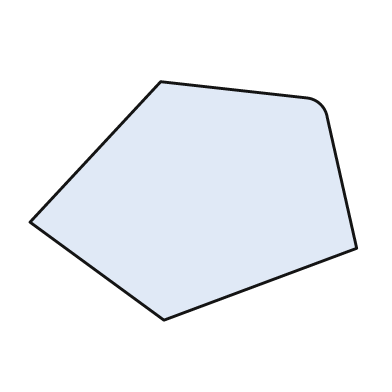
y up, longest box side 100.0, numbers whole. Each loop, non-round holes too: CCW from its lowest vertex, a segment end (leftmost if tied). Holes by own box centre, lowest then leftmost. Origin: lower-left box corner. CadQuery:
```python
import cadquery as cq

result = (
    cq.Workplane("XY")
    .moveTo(41.0, 0.0)
    .lineTo(100.0, 22.0)
    .lineTo(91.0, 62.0)
    .threePointArc((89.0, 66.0), (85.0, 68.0))
    .lineTo(40.0, 73.0)
    .lineTo(0.0, 30.0)
    .close()
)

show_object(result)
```